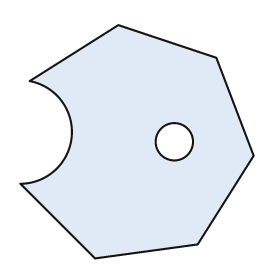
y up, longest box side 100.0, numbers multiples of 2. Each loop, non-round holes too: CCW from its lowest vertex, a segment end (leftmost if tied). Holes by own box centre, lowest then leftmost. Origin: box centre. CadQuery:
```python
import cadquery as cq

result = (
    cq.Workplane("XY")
    .moveTo(-18.0, -50.0)
    .lineTo(26.0, -44.0)
    .lineTo(50.0, -6.0)
    .lineTo(34.0, 36.0)
    .lineTo(-8.0, 50.0)
    .lineTo(-46.0, 26.0)
    .threePointArc((-28.0, 2.0), (-50.0, -18.0))
    .close()
    .moveTo(16.0, 0.0)
    .circle(8.0)
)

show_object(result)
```